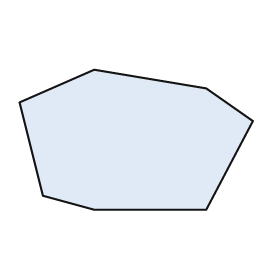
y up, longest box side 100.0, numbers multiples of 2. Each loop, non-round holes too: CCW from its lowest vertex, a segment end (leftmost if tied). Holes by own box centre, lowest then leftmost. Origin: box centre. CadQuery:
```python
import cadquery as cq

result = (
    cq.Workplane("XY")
    .moveTo(-18.0, -30.0)
    .lineTo(30.0, -30.0)
    .lineTo(50.0, 8.0)
    .lineTo(30.0, 22.0)
    .lineTo(-18.0, 30.0)
    .lineTo(-50.0, 16.0)
    .lineTo(-40.0, -24.0)
    .close()
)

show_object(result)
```